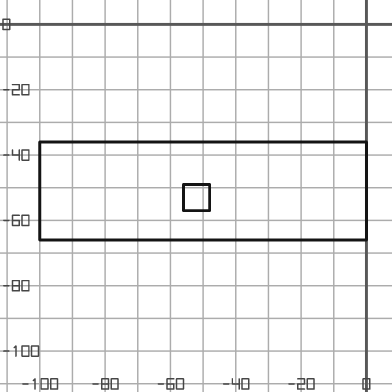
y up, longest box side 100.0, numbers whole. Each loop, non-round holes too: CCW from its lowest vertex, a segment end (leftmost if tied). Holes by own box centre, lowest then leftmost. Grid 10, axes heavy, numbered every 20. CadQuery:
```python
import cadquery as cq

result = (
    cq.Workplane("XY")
    .moveTo(-100.0, -66.0)
    .lineTo(0.0, -66.0)
    .lineTo(0.0, -36.0)
    .lineTo(-100.0, -36.0)
    .close()
    .moveTo(-56.0, -57.0)
    .lineTo(-48.0, -57.0)
    .lineTo(-48.0, -49.0)
    .lineTo(-56.0, -49.0)
    .close()
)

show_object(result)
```